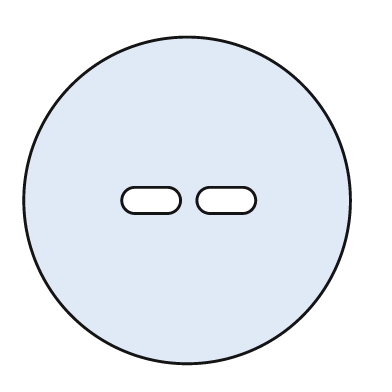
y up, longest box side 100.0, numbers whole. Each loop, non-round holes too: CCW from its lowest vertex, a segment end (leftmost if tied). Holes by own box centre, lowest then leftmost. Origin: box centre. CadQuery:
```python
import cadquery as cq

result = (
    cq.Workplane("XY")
    .moveTo(0.0, 0.0)
    .circle(50.0)
    .moveTo(-16.0, -4.0)
    .lineTo(-6.0, -4.0)
    .threePointArc((-2.0, 0.0), (-6.0, 4.0))
    .lineTo(-16.0, 4.0)
    .threePointArc((-20.0, 0.0), (-16.0, -4.0))
    .close()
    .moveTo(7.0, -4.0)
    .lineTo(17.0, -4.0)
    .threePointArc((21.0, 0.0), (17.0, 4.0))
    .lineTo(7.0, 4.0)
    .threePointArc((3.0, 0.0), (7.0, -4.0))
    .close()
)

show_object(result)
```